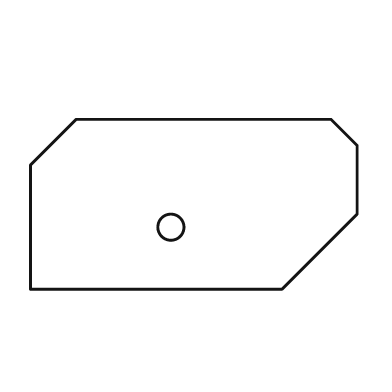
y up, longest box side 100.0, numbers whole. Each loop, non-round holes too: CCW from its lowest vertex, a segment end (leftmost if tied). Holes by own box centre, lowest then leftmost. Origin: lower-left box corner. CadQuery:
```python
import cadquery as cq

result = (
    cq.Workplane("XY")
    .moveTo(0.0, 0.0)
    .lineTo(77.0, 0.0)
    .lineTo(100.0, 23.0)
    .lineTo(100.0, 44.0)
    .lineTo(92.0, 52.0)
    .lineTo(14.0, 52.0)
    .lineTo(0.0, 38.0)
    .close()
    .moveTo(43.0, 19.0)
    .circle(4.0)
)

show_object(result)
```